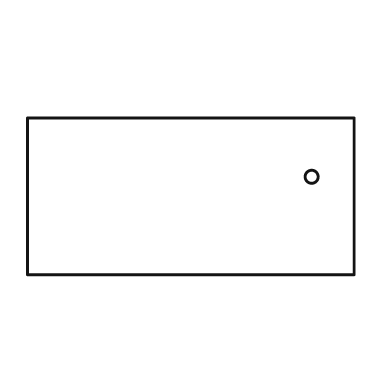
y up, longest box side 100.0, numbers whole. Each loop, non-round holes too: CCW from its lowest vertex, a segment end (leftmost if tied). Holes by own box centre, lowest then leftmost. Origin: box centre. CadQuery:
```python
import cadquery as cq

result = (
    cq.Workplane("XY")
    .moveTo(-50.0, -24.0)
    .lineTo(50.0, -24.0)
    .lineTo(50.0, 24.0)
    .lineTo(-50.0, 24.0)
    .close()
    .moveTo(37.0, 6.0)
    .circle(2.0)
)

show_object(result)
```